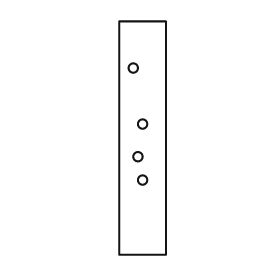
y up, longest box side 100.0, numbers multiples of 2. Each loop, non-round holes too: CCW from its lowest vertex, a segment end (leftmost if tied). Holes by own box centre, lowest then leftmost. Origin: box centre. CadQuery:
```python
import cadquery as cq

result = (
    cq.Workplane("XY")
    .moveTo(-10.0, -50.0)
    .lineTo(10.0, -50.0)
    .lineTo(10.0, 50.0)
    .lineTo(-10.0, 50.0)
    .close()
    .moveTo(0.0, -18.0)
    .circle(2.0)
    .moveTo(-2.0, -8.0)
    .circle(2.0)
    .moveTo(0.0, 6.0)
    .circle(2.0)
    .moveTo(-4.0, 30.0)
    .circle(2.0)
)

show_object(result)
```